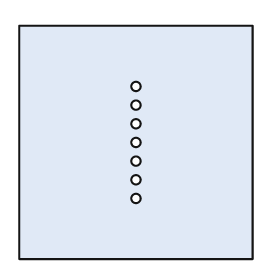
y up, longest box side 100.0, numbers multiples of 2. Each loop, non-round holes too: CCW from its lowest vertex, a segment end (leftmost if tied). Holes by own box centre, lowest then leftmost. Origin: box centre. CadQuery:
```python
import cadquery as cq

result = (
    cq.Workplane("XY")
    .moveTo(-50.0, -50.0)
    .lineTo(50.0, -50.0)
    .lineTo(50.0, 50.0)
    .lineTo(-50.0, 50.0)
    .close()
    .moveTo(0.0, -24.0)
    .circle(2.0)
    .moveTo(0.0, -16.0)
    .circle(2.0)
    .moveTo(0.0, -8.0)
    .circle(2.0)
    .moveTo(0.0, 0.0)
    .circle(2.0)
    .moveTo(0.0, 8.0)
    .circle(2.0)
    .moveTo(0.0, 16.0)
    .circle(2.0)
    .moveTo(0.0, 24.0)
    .circle(2.0)
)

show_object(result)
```